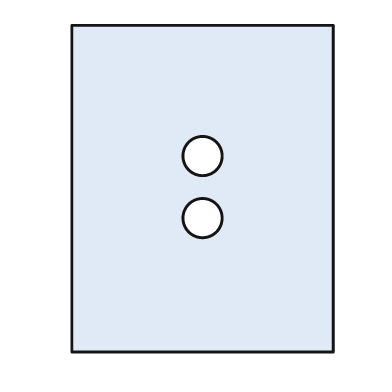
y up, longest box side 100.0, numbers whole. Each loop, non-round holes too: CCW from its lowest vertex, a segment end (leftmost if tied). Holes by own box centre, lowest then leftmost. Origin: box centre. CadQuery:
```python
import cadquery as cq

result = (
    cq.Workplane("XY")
    .moveTo(-40.0, -50.0)
    .lineTo(40.0, -50.0)
    .lineTo(40.0, 50.0)
    .lineTo(-40.0, 50.0)
    .close()
    .moveTo(0.0, -9.0)
    .circle(6.0)
    .moveTo(0.0, 10.0)
    .circle(6.0)
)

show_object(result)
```